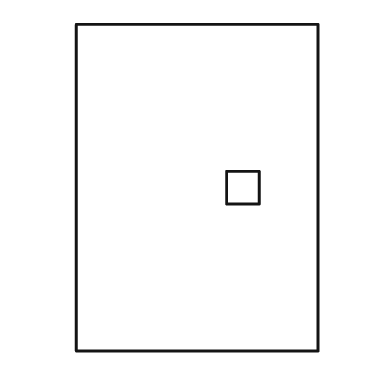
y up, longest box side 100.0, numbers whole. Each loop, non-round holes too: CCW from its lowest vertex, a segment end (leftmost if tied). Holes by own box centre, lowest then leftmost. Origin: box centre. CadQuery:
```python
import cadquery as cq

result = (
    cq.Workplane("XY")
    .moveTo(-37.0, -50.0)
    .lineTo(37.0, -50.0)
    .lineTo(37.0, 50.0)
    .lineTo(-37.0, 50.0)
    .close()
    .moveTo(9.0, -5.0)
    .lineTo(19.0, -5.0)
    .lineTo(19.0, 5.0)
    .lineTo(9.0, 5.0)
    .close()
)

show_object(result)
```